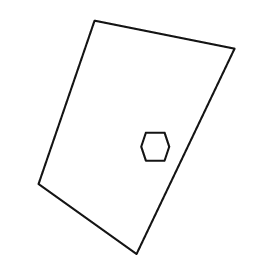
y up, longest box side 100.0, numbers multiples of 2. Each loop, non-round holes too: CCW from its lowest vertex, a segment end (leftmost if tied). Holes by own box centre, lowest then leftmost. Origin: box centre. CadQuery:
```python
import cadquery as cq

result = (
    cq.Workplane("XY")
    .moveTo(0.0, -50.0)
    .lineTo(42.0, 38.0)
    .lineTo(-18.0, 50.0)
    .lineTo(-42.0, -20.0)
    .close()
    .moveTo(4.0, -10.0)
    .lineTo(12.0, -10.0)
    .lineTo(14.0, -4.0)
    .lineTo(12.0, 2.0)
    .lineTo(4.0, 2.0)
    .lineTo(2.0, -4.0)
    .close()
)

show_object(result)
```